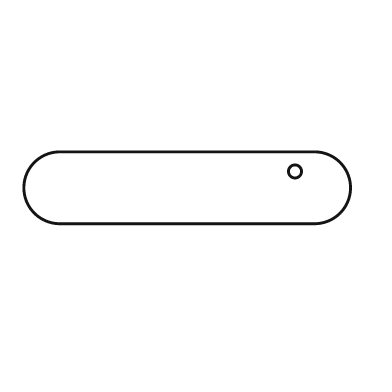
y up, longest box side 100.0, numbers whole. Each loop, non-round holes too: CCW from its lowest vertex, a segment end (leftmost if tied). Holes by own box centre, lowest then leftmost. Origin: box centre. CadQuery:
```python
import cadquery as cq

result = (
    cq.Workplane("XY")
    .moveTo(-39.0, -11.0)
    .lineTo(39.0, -11.0)
    .threePointArc((50.0, 0.0), (39.0, 11.0))
    .lineTo(-39.0, 11.0)
    .threePointArc((-50.0, 0.0), (-39.0, -11.0))
    .close()
    .moveTo(33.0, 5.0)
    .circle(2.0)
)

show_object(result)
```